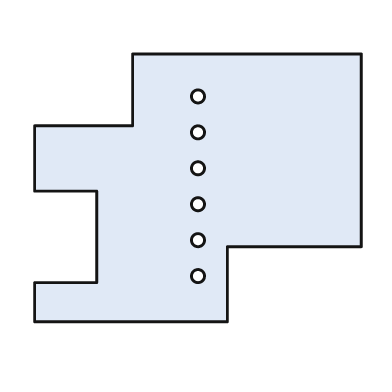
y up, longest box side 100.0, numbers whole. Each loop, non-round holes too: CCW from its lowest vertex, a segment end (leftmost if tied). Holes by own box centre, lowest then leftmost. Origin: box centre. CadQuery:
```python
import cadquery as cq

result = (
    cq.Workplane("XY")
    .moveTo(-50.0, -41.0)
    .lineTo(9.0, -41.0)
    .lineTo(9.0, -18.0)
    .lineTo(50.0, -18.0)
    .lineTo(50.0, 41.0)
    .lineTo(-20.0, 41.0)
    .lineTo(-20.0, 19.0)
    .lineTo(-50.0, 19.0)
    .lineTo(-50.0, -1.0)
    .lineTo(-31.0, -1.0)
    .lineTo(-31.0, -29.0)
    .lineTo(-50.0, -29.0)
    .close()
    .moveTo(0.0, -27.0)
    .circle(2.0)
    .moveTo(0.0, -16.0)
    .circle(2.0)
    .moveTo(0.0, -5.0)
    .circle(2.0)
    .moveTo(0.0, 6.0)
    .circle(2.0)
    .moveTo(0.0, 17.0)
    .circle(2.0)
    .moveTo(0.0, 28.0)
    .circle(2.0)
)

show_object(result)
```